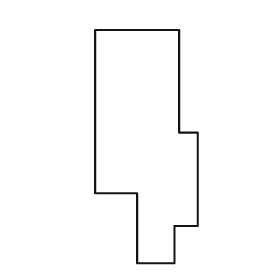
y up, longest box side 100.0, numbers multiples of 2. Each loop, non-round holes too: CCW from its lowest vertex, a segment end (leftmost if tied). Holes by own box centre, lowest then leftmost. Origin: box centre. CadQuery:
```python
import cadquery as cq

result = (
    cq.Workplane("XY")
    .moveTo(-4.0, -50.0)
    .lineTo(12.0, -50.0)
    .lineTo(12.0, -34.0)
    .lineTo(22.0, -34.0)
    .lineTo(22.0, 6.0)
    .lineTo(14.0, 6.0)
    .lineTo(14.0, 50.0)
    .lineTo(-22.0, 50.0)
    .lineTo(-22.0, -20.0)
    .lineTo(-4.0, -20.0)
    .close()
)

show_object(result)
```